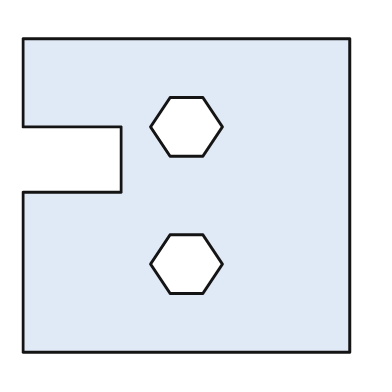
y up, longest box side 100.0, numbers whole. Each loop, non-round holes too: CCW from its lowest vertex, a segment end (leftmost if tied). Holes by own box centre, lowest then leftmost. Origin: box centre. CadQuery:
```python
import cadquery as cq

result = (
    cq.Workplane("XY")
    .moveTo(-50.0, -48.0)
    .lineTo(50.0, -48.0)
    .lineTo(50.0, 48.0)
    .lineTo(-50.0, 48.0)
    .lineTo(-50.0, 21.0)
    .lineTo(-20.0, 21.0)
    .lineTo(-20.0, 1.0)
    .lineTo(-50.0, 1.0)
    .close()
    .moveTo(-5.0, -30.0)
    .lineTo(5.0, -30.0)
    .lineTo(11.0, -21.0)
    .lineTo(5.0, -12.0)
    .lineTo(-5.0, -12.0)
    .lineTo(-11.0, -21.0)
    .close()
    .moveTo(-5.0, 12.0)
    .lineTo(5.0, 12.0)
    .lineTo(11.0, 21.0)
    .lineTo(5.0, 30.0)
    .lineTo(-5.0, 30.0)
    .lineTo(-11.0, 21.0)
    .close()
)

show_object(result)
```